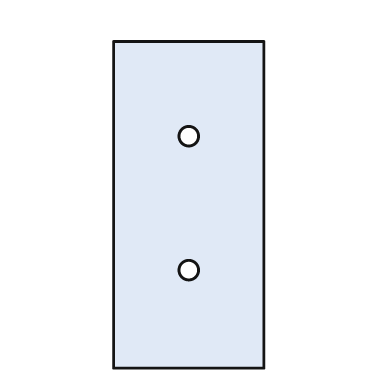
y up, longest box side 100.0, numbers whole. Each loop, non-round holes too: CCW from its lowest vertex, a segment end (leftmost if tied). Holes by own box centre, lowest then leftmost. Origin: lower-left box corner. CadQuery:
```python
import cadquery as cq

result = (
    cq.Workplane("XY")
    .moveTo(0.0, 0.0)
    .lineTo(46.0, 0.0)
    .lineTo(46.0, 100.0)
    .lineTo(0.0, 100.0)
    .close()
    .moveTo(23.0, 30.0)
    .circle(3.0)
    .moveTo(23.0, 71.0)
    .circle(3.0)
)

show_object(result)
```